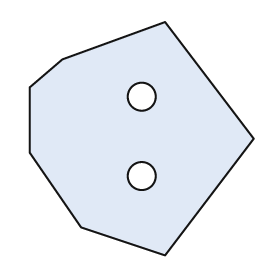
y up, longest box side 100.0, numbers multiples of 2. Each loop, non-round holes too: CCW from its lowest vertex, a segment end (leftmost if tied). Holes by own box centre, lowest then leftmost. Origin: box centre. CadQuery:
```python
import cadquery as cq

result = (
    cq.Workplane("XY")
    .moveTo(10.0, -50.0)
    .lineTo(48.0, 0.0)
    .lineTo(10.0, 50.0)
    .lineTo(-34.0, 34.0)
    .lineTo(-48.0, 22.0)
    .lineTo(-48.0, -6.0)
    .lineTo(-26.0, -38.0)
    .close()
    .moveTo(0.0, -16.0)
    .circle(6.0)
    .moveTo(0.0, 18.0)
    .circle(6.0)
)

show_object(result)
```